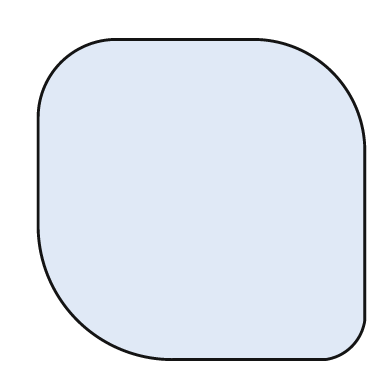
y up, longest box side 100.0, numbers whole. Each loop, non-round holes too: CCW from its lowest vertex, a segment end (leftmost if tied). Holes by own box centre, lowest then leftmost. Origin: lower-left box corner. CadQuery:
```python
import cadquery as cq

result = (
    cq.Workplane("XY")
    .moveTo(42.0, 0.0)
    .lineTo(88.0, 0.0)
    .threePointArc((96.0, 4.0), (100.0, 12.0))
    .lineTo(100.0, 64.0)
    .threePointArc((90.0, 88.0), (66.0, 98.0))
    .lineTo(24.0, 98.0)
    .threePointArc((7.0, 91.0), (0.0, 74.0))
    .lineTo(0.0, 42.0)
    .threePointArc((12.0, 12.0), (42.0, 0.0))
    .close()
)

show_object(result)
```